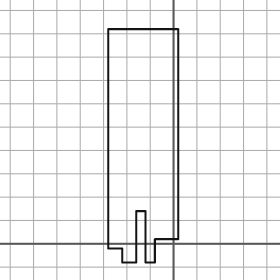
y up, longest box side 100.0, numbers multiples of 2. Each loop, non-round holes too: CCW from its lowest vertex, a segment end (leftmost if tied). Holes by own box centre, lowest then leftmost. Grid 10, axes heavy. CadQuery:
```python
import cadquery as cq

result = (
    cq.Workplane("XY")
    .moveTo(-22.0, -8.0)
    .lineTo(-16.0, -8.0)
    .lineTo(-16.0, 14.0)
    .lineTo(-12.0, 14.0)
    .lineTo(-12.0, -8.0)
    .lineTo(-8.0, -8.0)
    .lineTo(-8.0, 2.0)
    .lineTo(2.0, 2.0)
    .lineTo(2.0, 92.0)
    .lineTo(-28.0, 92.0)
    .lineTo(-28.0, -2.0)
    .lineTo(-22.0, -2.0)
    .close()
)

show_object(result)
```